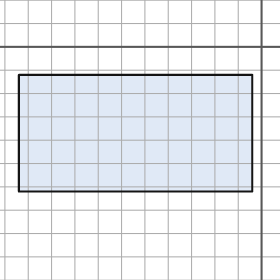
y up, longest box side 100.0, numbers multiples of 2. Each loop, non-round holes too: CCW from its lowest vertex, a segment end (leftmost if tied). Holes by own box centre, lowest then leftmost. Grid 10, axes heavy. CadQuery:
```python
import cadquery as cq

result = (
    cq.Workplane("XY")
    .moveTo(-104.0, -62.0)
    .lineTo(-4.0, -62.0)
    .lineTo(-4.0, -12.0)
    .lineTo(-104.0, -12.0)
    .close()
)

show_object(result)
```